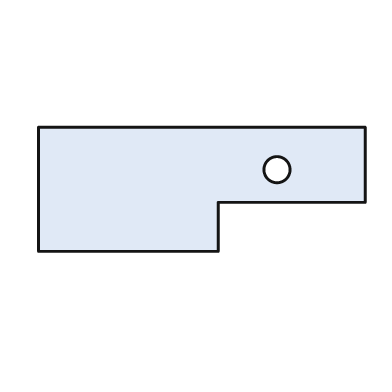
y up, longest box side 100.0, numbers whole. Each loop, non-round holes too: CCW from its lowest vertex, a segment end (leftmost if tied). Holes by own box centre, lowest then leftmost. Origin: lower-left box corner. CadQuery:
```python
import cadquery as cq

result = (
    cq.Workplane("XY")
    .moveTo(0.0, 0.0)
    .lineTo(55.0, 0.0)
    .lineTo(55.0, 15.0)
    .lineTo(100.0, 15.0)
    .lineTo(100.0, 38.0)
    .lineTo(0.0, 38.0)
    .close()
    .moveTo(73.0, 25.0)
    .circle(4.0)
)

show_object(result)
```